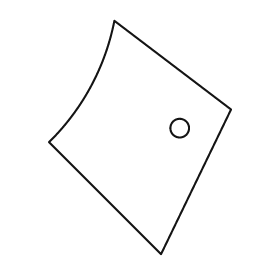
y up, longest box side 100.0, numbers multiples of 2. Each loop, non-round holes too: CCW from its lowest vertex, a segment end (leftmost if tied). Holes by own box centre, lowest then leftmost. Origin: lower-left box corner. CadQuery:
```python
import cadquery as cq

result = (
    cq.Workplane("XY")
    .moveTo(48.0, 0.0)
    .lineTo(78.0, 62.0)
    .lineTo(28.0, 100.0)
    .threePointArc((18.0, 72.0), (0.0, 48.0))
    .close()
    .moveTo(56.0, 54.0)
    .circle(4.0)
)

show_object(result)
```